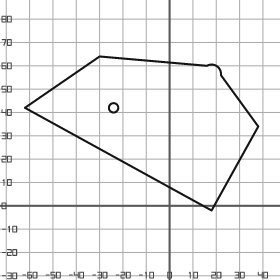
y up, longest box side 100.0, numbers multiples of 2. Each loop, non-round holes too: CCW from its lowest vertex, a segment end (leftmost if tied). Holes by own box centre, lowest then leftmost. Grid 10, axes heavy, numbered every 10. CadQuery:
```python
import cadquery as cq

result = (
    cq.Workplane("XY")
    .moveTo(18.0, -2.0)
    .lineTo(38.0, 34.0)
    .lineTo(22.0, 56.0)
    .threePointArc((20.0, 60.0), (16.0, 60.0))
    .lineTo(-30.0, 64.0)
    .lineTo(-62.0, 42.0)
    .close()
    .moveTo(-24.0, 42.0)
    .circle(2.0)
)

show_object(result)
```